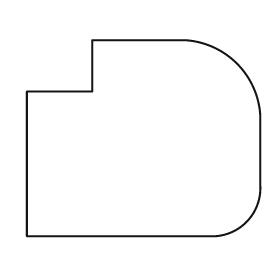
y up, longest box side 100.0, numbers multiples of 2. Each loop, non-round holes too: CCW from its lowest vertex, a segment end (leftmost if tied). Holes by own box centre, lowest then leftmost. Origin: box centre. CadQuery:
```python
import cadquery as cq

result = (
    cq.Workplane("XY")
    .moveTo(-50.0, -42.0)
    .lineTo(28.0, -42.0)
    .threePointArc((44.0, -36.0), (50.0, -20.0))
    .lineTo(50.0, 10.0)
    .threePointArc((40.0, 32.0), (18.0, 42.0))
    .lineTo(-22.0, 42.0)
    .lineTo(-22.0, 20.0)
    .lineTo(-50.0, 20.0)
    .close()
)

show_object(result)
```